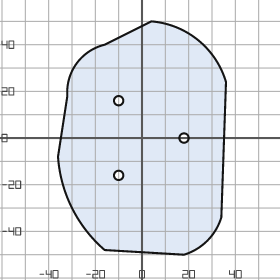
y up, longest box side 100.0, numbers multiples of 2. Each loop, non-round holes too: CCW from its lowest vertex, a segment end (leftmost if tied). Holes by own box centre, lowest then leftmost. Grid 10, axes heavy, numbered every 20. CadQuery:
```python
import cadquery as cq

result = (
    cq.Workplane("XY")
    .moveTo(18.0, -50.0)
    .threePointArc((28.0, -44.0), (34.0, -34.0))
    .lineTo(36.0, 24.0)
    .threePointArc((24.0, 42.0), (4.0, 50.0))
    .lineTo(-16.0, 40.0)
    .threePointArc((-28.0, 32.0), (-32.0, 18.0))
    .lineTo(-36.0, -8.0)
    .threePointArc((-30.0, -30.0), (-16.0, -48.0))
    .close()
    .moveTo(-10.0, -16.0)
    .circle(2.0)
    .moveTo(18.0, 0.0)
    .circle(2.0)
    .moveTo(-10.0, 16.0)
    .circle(2.0)
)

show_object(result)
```